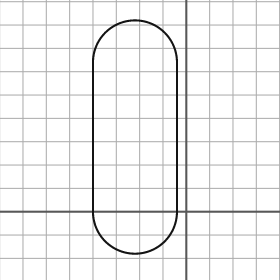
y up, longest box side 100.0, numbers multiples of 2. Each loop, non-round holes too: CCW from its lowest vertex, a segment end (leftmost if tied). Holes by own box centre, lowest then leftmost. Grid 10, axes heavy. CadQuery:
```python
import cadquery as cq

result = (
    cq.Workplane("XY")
    .moveTo(-40.0, 0.0)
    .threePointArc((-22.0, -18.0), (-4.0, 0.0))
    .lineTo(-4.0, 64.0)
    .threePointArc((-22.0, 82.0), (-40.0, 64.0))
    .close()
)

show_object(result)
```